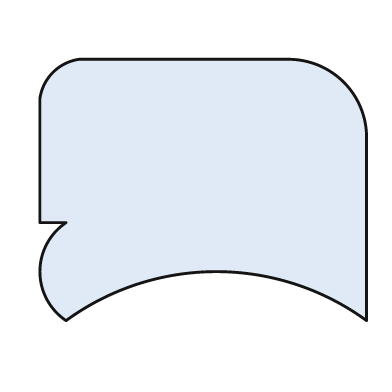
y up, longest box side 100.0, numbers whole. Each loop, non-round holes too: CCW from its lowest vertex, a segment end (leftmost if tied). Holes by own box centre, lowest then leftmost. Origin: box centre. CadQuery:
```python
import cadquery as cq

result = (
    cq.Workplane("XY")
    .moveTo(-42.0, -40.0)
    .threePointArc((4.0, -25.0), (50.0, -40.0))
    .lineTo(50.0, 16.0)
    .threePointArc((43.0, 33.0), (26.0, 40.0))
    .lineTo(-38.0, 40.0)
    .threePointArc((-46.0, 36.0), (-50.0, 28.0))
    .lineTo(-50.0, -10.0)
    .lineTo(-42.0, -10.0)
    .threePointArc((-50.0, -25.0), (-42.0, -40.0))
    .close()
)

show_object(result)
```